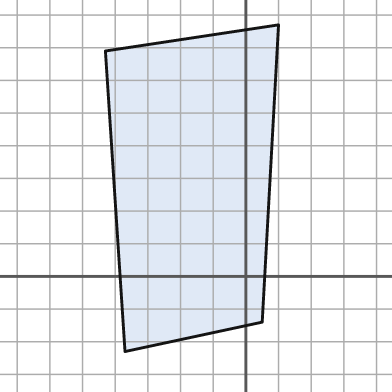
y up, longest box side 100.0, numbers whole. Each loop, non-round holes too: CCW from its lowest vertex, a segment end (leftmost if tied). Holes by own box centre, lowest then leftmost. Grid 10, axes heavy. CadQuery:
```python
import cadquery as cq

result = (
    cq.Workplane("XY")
    .moveTo(-37.0, -23.0)
    .lineTo(5.0, -14.0)
    .lineTo(10.0, 77.0)
    .lineTo(-43.0, 69.0)
    .close()
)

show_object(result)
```